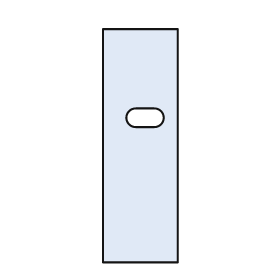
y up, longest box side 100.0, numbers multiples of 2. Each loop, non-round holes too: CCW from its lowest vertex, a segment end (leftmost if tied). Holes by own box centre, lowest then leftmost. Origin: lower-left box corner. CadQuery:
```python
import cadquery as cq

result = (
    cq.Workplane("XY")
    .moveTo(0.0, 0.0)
    .lineTo(32.0, 0.0)
    .lineTo(32.0, 100.0)
    .lineTo(0.0, 100.0)
    .close()
    .moveTo(14.0, 58.0)
    .lineTo(22.0, 58.0)
    .threePointArc((26.0, 62.0), (22.0, 66.0))
    .lineTo(14.0, 66.0)
    .threePointArc((10.0, 62.0), (14.0, 58.0))
    .close()
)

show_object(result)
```